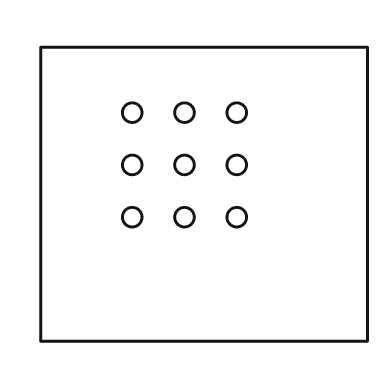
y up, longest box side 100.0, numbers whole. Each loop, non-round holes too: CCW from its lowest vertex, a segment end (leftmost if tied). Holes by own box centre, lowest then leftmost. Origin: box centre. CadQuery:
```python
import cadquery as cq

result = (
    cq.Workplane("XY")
    .moveTo(-50.0, -45.0)
    .lineTo(50.0, -45.0)
    .lineTo(50.0, 45.0)
    .lineTo(-50.0, 45.0)
    .close()
    .moveTo(-22.0, -7.0)
    .circle(3.0)
    .moveTo(-6.0, -7.0)
    .circle(3.0)
    .moveTo(10.0, -7.0)
    .circle(3.0)
    .moveTo(-22.0, 9.0)
    .circle(3.0)
    .moveTo(-6.0, 9.0)
    .circle(3.0)
    .moveTo(10.0, 9.0)
    .circle(3.0)
    .moveTo(-22.0, 25.0)
    .circle(3.0)
    .moveTo(-6.0, 25.0)
    .circle(3.0)
    .moveTo(10.0, 25.0)
    .circle(3.0)
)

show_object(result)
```